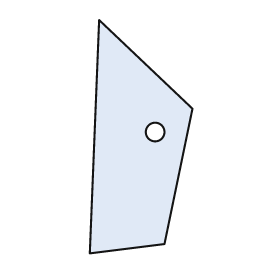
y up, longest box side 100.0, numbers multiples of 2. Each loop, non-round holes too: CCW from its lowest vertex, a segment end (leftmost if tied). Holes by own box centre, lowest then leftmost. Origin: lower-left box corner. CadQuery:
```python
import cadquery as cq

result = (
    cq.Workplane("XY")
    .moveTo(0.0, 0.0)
    .lineTo(32.0, 4.0)
    .lineTo(44.0, 62.0)
    .lineTo(4.0, 100.0)
    .close()
    .moveTo(28.0, 52.0)
    .circle(4.0)
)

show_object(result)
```